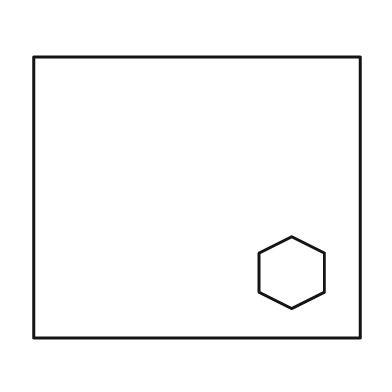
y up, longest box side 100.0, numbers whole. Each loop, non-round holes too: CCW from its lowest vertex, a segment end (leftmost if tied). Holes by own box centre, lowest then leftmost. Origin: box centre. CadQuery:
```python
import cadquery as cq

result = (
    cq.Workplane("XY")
    .moveTo(-50.0, -43.0)
    .lineTo(50.0, -43.0)
    .lineTo(50.0, 43.0)
    .lineTo(-50.0, 43.0)
    .close()
    .moveTo(29.0, -34.0)
    .lineTo(39.0, -29.0)
    .lineTo(39.0, -17.0)
    .lineTo(29.0, -12.0)
    .lineTo(19.0, -17.0)
    .lineTo(19.0, -29.0)
    .close()
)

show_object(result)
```